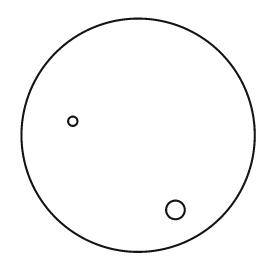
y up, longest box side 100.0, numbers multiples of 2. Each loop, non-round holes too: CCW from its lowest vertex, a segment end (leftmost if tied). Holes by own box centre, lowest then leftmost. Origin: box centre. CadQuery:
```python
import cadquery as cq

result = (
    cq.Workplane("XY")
    .moveTo(0.0, 0.0)
    .circle(50.0)
    .moveTo(16.0, -32.0)
    .circle(4.0)
    .moveTo(-28.0, 6.0)
    .circle(2.0)
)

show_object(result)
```